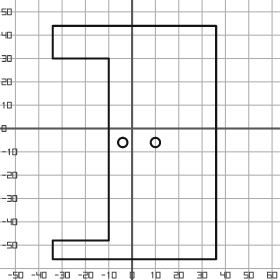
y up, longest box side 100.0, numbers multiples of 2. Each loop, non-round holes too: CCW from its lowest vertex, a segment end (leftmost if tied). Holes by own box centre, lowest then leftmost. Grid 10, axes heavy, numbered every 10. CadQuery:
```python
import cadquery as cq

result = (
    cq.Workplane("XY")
    .moveTo(-34.0, -56.0)
    .lineTo(36.0, -56.0)
    .lineTo(36.0, 44.0)
    .lineTo(-34.0, 44.0)
    .lineTo(-34.0, 30.0)
    .lineTo(-10.0, 30.0)
    .lineTo(-10.0, -48.0)
    .lineTo(-34.0, -48.0)
    .close()
    .moveTo(-4.0, -6.0)
    .circle(2.0)
    .moveTo(10.0, -6.0)
    .circle(2.0)
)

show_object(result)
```